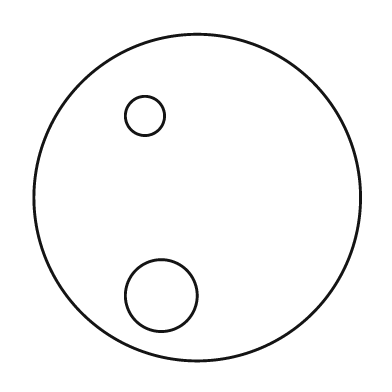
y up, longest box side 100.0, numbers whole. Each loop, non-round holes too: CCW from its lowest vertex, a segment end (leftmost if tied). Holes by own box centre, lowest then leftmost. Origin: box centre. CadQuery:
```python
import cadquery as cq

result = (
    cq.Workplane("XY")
    .moveTo(0.0, 0.0)
    .circle(50.0)
    .moveTo(-11.0, -30.0)
    .circle(11.0)
    .moveTo(-16.0, 25.0)
    .circle(6.0)
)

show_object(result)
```